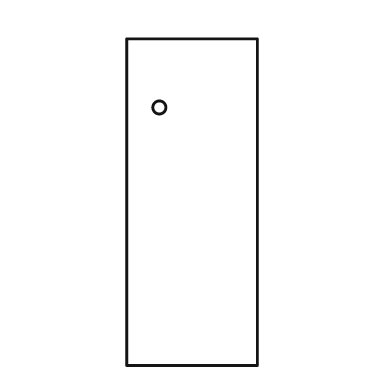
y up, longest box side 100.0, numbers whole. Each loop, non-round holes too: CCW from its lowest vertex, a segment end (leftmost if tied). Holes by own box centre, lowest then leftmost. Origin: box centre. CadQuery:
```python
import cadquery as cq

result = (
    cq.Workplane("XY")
    .moveTo(-20.0, -50.0)
    .lineTo(20.0, -50.0)
    .lineTo(20.0, 50.0)
    .lineTo(-20.0, 50.0)
    .close()
    .moveTo(-10.0, 29.0)
    .circle(2.0)
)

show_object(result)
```